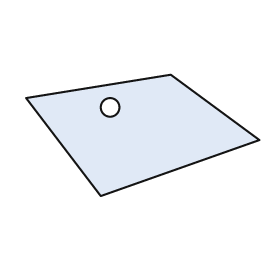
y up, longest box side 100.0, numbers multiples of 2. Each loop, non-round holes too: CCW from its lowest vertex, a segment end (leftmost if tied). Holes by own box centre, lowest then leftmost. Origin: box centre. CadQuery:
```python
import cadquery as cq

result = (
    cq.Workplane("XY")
    .moveTo(-18.0, -26.0)
    .lineTo(50.0, -2.0)
    .lineTo(12.0, 26.0)
    .lineTo(-50.0, 16.0)
    .close()
    .moveTo(-14.0, 12.0)
    .circle(4.0)
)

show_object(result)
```